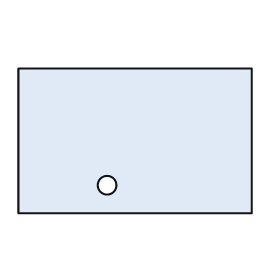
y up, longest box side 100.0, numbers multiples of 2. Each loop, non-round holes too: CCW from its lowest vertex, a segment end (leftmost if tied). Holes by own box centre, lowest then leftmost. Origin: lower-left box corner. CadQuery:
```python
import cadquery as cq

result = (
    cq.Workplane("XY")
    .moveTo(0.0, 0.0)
    .lineTo(100.0, 0.0)
    .lineTo(100.0, 62.0)
    .lineTo(0.0, 62.0)
    .close()
    .moveTo(38.0, 12.0)
    .circle(4.0)
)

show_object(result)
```